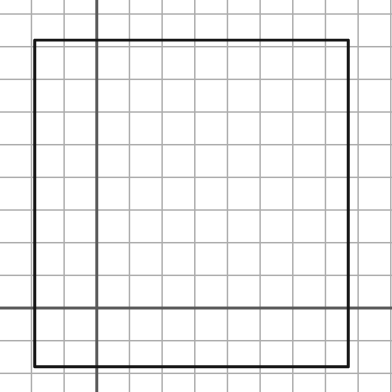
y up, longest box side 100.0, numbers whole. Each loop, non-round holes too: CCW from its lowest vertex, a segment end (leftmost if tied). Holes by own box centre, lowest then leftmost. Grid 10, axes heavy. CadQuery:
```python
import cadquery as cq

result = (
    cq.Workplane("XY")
    .moveTo(-19.0, -18.0)
    .lineTo(77.0, -18.0)
    .lineTo(77.0, 82.0)
    .lineTo(-19.0, 82.0)
    .close()
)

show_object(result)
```